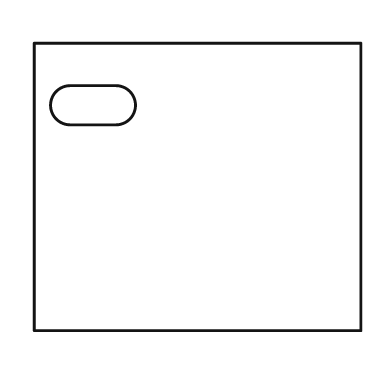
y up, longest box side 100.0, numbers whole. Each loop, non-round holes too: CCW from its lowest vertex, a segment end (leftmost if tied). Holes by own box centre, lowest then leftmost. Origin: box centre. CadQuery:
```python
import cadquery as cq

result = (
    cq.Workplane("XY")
    .moveTo(-50.0, -44.0)
    .lineTo(50.0, -44.0)
    .lineTo(50.0, 44.0)
    .lineTo(-50.0, 44.0)
    .close()
    .moveTo(-39.0, 19.0)
    .lineTo(-25.0, 19.0)
    .threePointArc((-19.0, 25.0), (-25.0, 31.0))
    .lineTo(-39.0, 31.0)
    .threePointArc((-45.0, 25.0), (-39.0, 19.0))
    .close()
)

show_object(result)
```